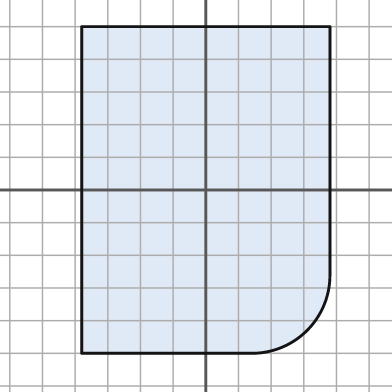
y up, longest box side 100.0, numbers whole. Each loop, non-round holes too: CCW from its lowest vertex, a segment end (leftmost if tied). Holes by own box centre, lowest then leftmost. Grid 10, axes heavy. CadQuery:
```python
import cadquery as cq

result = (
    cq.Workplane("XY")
    .moveTo(-38.0, -50.0)
    .lineTo(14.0, -50.0)
    .threePointArc((31.0, -43.0), (38.0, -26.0))
    .lineTo(38.0, 50.0)
    .lineTo(-38.0, 50.0)
    .close()
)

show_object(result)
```